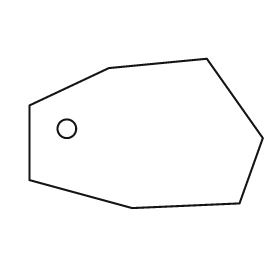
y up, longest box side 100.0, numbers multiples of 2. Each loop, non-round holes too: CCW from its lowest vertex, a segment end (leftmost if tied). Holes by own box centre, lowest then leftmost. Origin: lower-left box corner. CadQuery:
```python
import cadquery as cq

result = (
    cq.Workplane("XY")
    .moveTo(44.0, 0.0)
    .lineTo(90.0, 2.0)
    .lineTo(100.0, 30.0)
    .lineTo(76.0, 64.0)
    .lineTo(34.0, 60.0)
    .lineTo(0.0, 44.0)
    .lineTo(0.0, 12.0)
    .close()
    .moveTo(16.0, 34.0)
    .circle(4.0)
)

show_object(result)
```